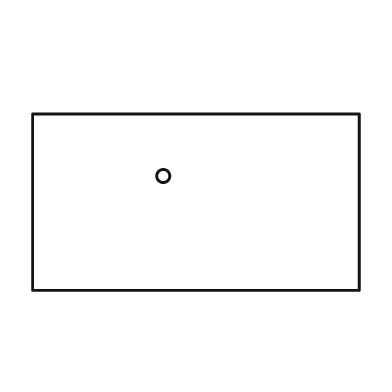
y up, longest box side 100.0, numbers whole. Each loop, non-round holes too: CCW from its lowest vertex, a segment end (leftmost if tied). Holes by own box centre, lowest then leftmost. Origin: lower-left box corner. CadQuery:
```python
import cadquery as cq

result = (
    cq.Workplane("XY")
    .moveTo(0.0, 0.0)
    .lineTo(100.0, 0.0)
    .lineTo(100.0, 54.0)
    .lineTo(0.0, 54.0)
    .close()
    .moveTo(40.0, 35.0)
    .circle(2.0)
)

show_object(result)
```